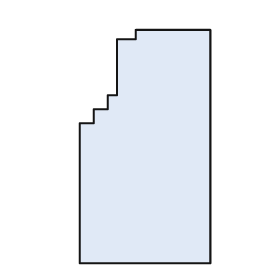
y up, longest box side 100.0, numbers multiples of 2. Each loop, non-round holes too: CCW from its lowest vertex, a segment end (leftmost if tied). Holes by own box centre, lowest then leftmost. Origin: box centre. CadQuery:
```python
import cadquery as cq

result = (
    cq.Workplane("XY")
    .moveTo(-28.0, -50.0)
    .lineTo(28.0, -50.0)
    .lineTo(28.0, 50.0)
    .lineTo(-4.0, 50.0)
    .lineTo(-4.0, 46.0)
    .lineTo(-12.0, 46.0)
    .lineTo(-12.0, 22.0)
    .lineTo(-16.0, 22.0)
    .lineTo(-16.0, 16.0)
    .lineTo(-22.0, 16.0)
    .lineTo(-22.0, 10.0)
    .lineTo(-28.0, 10.0)
    .close()
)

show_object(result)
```